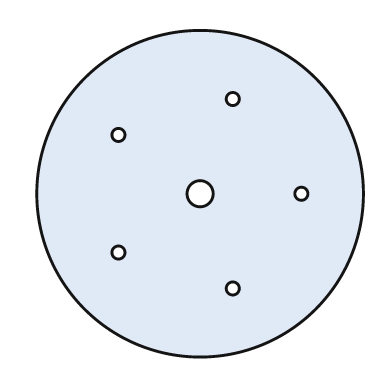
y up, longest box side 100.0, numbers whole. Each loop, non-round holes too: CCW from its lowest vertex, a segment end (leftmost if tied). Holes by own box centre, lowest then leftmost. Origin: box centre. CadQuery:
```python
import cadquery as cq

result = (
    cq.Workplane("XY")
    .moveTo(0.0, 0.0)
    .circle(50.0)
    .moveTo(10.0, -29.0)
    .circle(2.0)
    .moveTo(-25.0, -18.0)
    .circle(2.0)
    .moveTo(0.0, 0.0)
    .circle(4.0)
    .moveTo(31.0, 0.0)
    .circle(2.0)
    .moveTo(-25.0, 18.0)
    .circle(2.0)
    .moveTo(10.0, 29.0)
    .circle(2.0)
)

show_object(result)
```